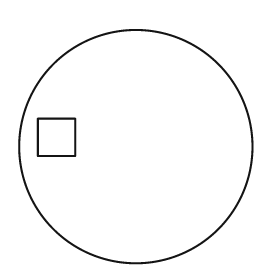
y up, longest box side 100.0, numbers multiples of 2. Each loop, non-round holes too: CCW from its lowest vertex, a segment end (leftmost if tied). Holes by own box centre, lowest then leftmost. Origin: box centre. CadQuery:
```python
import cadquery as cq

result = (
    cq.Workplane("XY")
    .moveTo(0.0, 0.0)
    .circle(50.0)
    .moveTo(-42.0, -4.0)
    .lineTo(-26.0, -4.0)
    .lineTo(-26.0, 12.0)
    .lineTo(-42.0, 12.0)
    .close()
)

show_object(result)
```